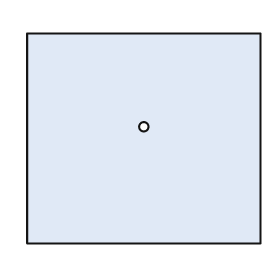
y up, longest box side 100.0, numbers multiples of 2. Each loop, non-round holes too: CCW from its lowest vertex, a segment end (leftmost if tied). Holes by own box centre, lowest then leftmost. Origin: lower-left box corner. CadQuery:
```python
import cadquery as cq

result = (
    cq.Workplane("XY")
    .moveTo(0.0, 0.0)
    .lineTo(100.0, 0.0)
    .lineTo(100.0, 90.0)
    .lineTo(0.0, 90.0)
    .close()
    .moveTo(50.0, 50.0)
    .circle(2.0)
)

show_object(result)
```